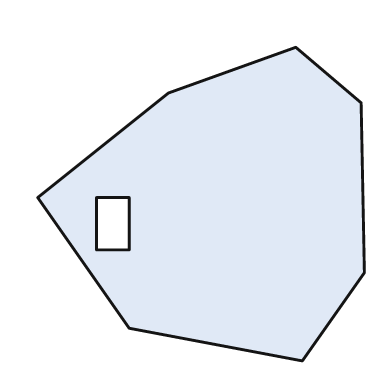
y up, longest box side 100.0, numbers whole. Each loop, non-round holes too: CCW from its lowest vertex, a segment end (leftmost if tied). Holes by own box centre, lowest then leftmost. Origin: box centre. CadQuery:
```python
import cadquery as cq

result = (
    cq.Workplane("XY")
    .moveTo(31.0, -48.0)
    .lineTo(50.0, -21.0)
    .lineTo(49.0, 31.0)
    .lineTo(29.0, 48.0)
    .lineTo(-10.0, 34.0)
    .lineTo(-50.0, 2.0)
    .lineTo(-22.0, -38.0)
    .close()
    .moveTo(-32.0, -14.0)
    .lineTo(-22.0, -14.0)
    .lineTo(-22.0, 2.0)
    .lineTo(-32.0, 2.0)
    .close()
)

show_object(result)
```